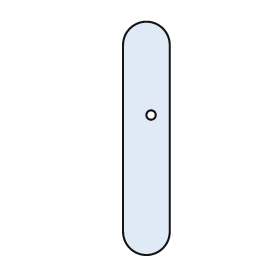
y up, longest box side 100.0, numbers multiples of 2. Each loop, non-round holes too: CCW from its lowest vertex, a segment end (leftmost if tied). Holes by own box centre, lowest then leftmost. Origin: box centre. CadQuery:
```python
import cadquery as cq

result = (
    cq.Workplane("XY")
    .moveTo(-10.0, -40.0)
    .threePointArc((0.0, -50.0), (10.0, -40.0))
    .lineTo(10.0, 40.0)
    .threePointArc((0.0, 50.0), (-10.0, 40.0))
    .close()
    .moveTo(2.0, 10.0)
    .circle(2.0)
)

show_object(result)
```